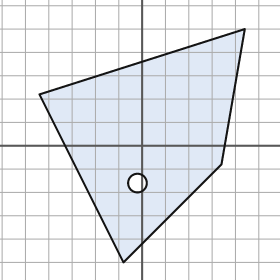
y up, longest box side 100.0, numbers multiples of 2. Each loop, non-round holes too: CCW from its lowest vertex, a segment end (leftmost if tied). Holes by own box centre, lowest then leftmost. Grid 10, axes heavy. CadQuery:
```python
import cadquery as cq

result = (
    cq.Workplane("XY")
    .moveTo(-8.0, -50.0)
    .lineTo(34.0, -8.0)
    .lineTo(44.0, 50.0)
    .lineTo(-44.0, 22.0)
    .close()
    .moveTo(-2.0, -16.0)
    .circle(4.0)
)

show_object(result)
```